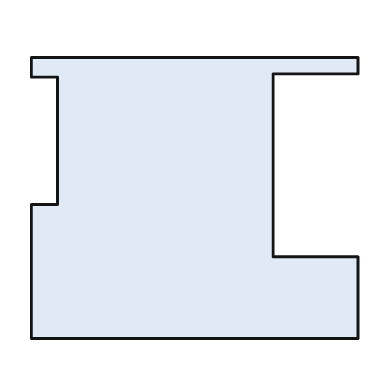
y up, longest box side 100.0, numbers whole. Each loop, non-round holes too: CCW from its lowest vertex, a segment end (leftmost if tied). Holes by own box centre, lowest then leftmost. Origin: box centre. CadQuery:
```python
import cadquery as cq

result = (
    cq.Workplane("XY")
    .moveTo(-50.0, -43.0)
    .lineTo(50.0, -43.0)
    .lineTo(50.0, -18.0)
    .lineTo(24.0, -18.0)
    .lineTo(24.0, 38.0)
    .lineTo(50.0, 38.0)
    .lineTo(50.0, 43.0)
    .lineTo(-50.0, 43.0)
    .lineTo(-50.0, 37.0)
    .lineTo(-42.0, 37.0)
    .lineTo(-42.0, -2.0)
    .lineTo(-50.0, -2.0)
    .close()
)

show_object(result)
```